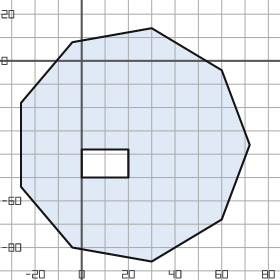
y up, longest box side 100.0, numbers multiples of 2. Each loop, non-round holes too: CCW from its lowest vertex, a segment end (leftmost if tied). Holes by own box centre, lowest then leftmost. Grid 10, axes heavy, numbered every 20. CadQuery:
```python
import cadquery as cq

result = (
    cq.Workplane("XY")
    .moveTo(30.0, -86.0)
    .lineTo(60.0, -68.0)
    .lineTo(72.0, -36.0)
    .lineTo(60.0, -4.0)
    .lineTo(30.0, 14.0)
    .lineTo(-4.0, 8.0)
    .lineTo(-26.0, -18.0)
    .lineTo(-26.0, -54.0)
    .lineTo(-4.0, -80.0)
    .close()
    .moveTo(0.0, -50.0)
    .lineTo(20.0, -50.0)
    .lineTo(20.0, -38.0)
    .lineTo(0.0, -38.0)
    .close()
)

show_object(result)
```